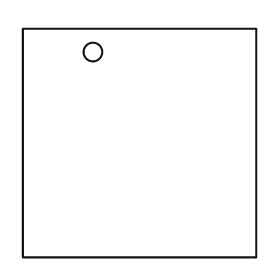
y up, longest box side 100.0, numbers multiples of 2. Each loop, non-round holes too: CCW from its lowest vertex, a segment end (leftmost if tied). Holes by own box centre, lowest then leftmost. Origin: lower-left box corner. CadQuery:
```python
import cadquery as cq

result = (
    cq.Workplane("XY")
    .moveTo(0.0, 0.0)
    .lineTo(100.0, 0.0)
    .lineTo(100.0, 98.0)
    .lineTo(0.0, 98.0)
    .close()
    .moveTo(30.0, 88.0)
    .circle(4.0)
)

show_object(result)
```